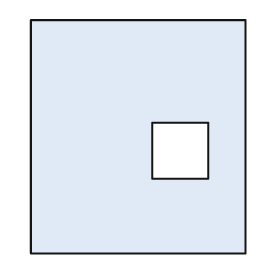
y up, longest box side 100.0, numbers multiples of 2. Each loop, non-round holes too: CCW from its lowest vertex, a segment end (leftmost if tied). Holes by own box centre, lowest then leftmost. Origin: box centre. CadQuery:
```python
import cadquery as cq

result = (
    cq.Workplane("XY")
    .moveTo(-46.0, -50.0)
    .lineTo(46.0, -50.0)
    .lineTo(46.0, 50.0)
    .lineTo(-46.0, 50.0)
    .close()
    .moveTo(6.0, -18.0)
    .lineTo(30.0, -18.0)
    .lineTo(30.0, 6.0)
    .lineTo(6.0, 6.0)
    .close()
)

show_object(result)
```